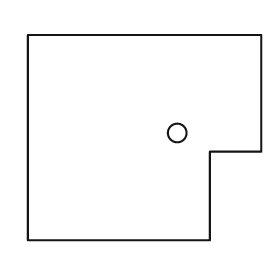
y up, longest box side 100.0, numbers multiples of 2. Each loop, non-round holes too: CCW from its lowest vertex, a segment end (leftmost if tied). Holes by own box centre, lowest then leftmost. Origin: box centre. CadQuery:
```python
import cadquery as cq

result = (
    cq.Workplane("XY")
    .moveTo(-50.0, -44.0)
    .lineTo(28.0, -44.0)
    .lineTo(28.0, -6.0)
    .lineTo(50.0, -6.0)
    .lineTo(50.0, 44.0)
    .lineTo(-50.0, 44.0)
    .close()
    .moveTo(14.0, 2.0)
    .circle(4.0)
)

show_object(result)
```